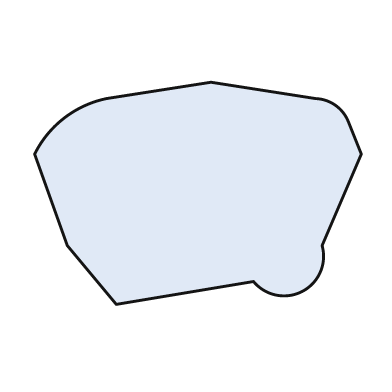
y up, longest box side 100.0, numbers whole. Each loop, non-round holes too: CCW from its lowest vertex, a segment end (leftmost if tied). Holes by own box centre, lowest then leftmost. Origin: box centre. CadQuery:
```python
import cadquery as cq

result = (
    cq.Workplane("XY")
    .moveTo(-25.0, -34.0)
    .lineTo(17.0, -27.0)
    .threePointArc((32.0, -30.0), (38.0, -16.0))
    .lineTo(50.0, 12.0)
    .lineTo(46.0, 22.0)
    .threePointArc((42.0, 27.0), (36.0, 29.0))
    .lineTo(4.0, 34.0)
    .lineTo(-28.0, 29.0)
    .threePointArc((-41.0, 23.0), (-50.0, 12.0))
    .lineTo(-40.0, -16.0)
    .close()
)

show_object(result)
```